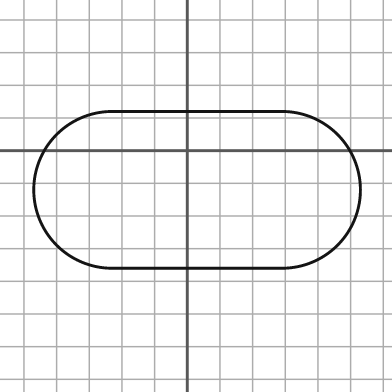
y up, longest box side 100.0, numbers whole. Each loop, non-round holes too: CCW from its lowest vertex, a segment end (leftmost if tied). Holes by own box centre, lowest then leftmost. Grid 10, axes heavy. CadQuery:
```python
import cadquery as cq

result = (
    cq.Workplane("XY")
    .moveTo(-23.0, -36.0)
    .lineTo(29.0, -36.0)
    .threePointArc((53.0, -12.0), (29.0, 12.0))
    .lineTo(-23.0, 12.0)
    .threePointArc((-47.0, -12.0), (-23.0, -36.0))
    .close()
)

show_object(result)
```